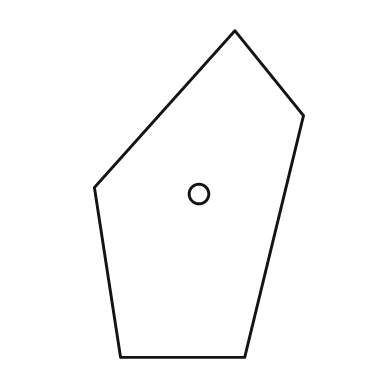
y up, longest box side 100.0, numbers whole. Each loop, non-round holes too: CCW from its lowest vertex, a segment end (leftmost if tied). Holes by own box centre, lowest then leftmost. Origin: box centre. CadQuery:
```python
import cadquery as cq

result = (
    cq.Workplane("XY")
    .moveTo(-24.0, -50.0)
    .lineTo(14.0, -50.0)
    .lineTo(32.0, 24.0)
    .lineTo(11.0, 50.0)
    .lineTo(-32.0, 2.0)
    .close()
    .moveTo(0.0, 0.0)
    .circle(3.0)
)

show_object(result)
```